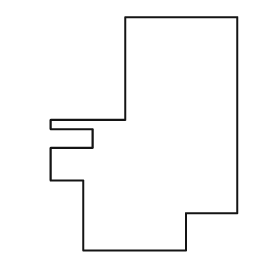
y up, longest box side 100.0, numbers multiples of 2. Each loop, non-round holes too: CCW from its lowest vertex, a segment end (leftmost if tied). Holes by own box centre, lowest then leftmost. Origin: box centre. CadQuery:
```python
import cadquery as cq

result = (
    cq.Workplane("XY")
    .moveTo(-26.0, -50.0)
    .lineTo(18.0, -50.0)
    .lineTo(18.0, -34.0)
    .lineTo(40.0, -34.0)
    .lineTo(40.0, 50.0)
    .lineTo(-8.0, 50.0)
    .lineTo(-8.0, 6.0)
    .lineTo(-40.0, 6.0)
    .lineTo(-40.0, 2.0)
    .lineTo(-22.0, 2.0)
    .lineTo(-22.0, -6.0)
    .lineTo(-40.0, -6.0)
    .lineTo(-40.0, -20.0)
    .lineTo(-26.0, -20.0)
    .close()
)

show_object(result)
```